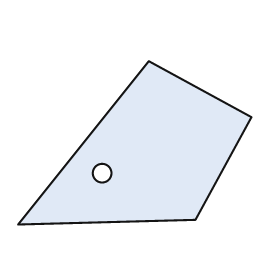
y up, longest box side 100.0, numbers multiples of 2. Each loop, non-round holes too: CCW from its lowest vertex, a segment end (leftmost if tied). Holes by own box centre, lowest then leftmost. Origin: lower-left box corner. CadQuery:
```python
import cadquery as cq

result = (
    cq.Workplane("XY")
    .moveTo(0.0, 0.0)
    .lineTo(76.0, 2.0)
    .lineTo(100.0, 46.0)
    .lineTo(56.0, 70.0)
    .close()
    .moveTo(36.0, 22.0)
    .circle(4.0)
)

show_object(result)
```